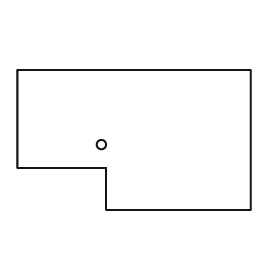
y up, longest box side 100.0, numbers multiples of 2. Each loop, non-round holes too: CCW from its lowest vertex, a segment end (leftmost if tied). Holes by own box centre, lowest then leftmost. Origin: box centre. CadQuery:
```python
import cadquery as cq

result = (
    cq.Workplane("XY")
    .moveTo(-12.0, -30.0)
    .lineTo(50.0, -30.0)
    .lineTo(50.0, 30.0)
    .lineTo(-50.0, 30.0)
    .lineTo(-50.0, -12.0)
    .lineTo(-12.0, -12.0)
    .close()
    .moveTo(-14.0, -2.0)
    .circle(2.0)
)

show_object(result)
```